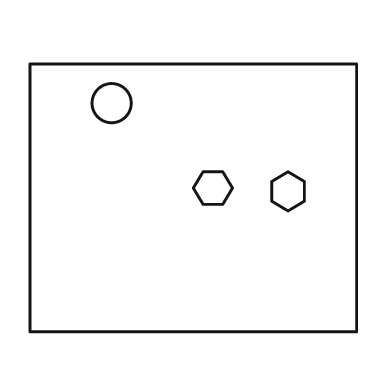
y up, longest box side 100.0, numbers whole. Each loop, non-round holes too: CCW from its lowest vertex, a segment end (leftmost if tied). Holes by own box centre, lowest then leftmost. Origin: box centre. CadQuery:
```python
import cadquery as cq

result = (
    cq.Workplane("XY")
    .moveTo(-50.0, -41.0)
    .lineTo(50.0, -41.0)
    .lineTo(50.0, 41.0)
    .lineTo(-50.0, 41.0)
    .close()
    .moveTo(29.0, -4.0)
    .lineTo(34.0, -1.0)
    .lineTo(34.0, 5.0)
    .lineTo(29.0, 8.0)
    .lineTo(24.0, 5.0)
    .lineTo(24.0, -1.0)
    .close()
    .moveTo(3.0, -2.0)
    .lineTo(9.0, -2.0)
    .lineTo(12.0, 3.0)
    .lineTo(9.0, 8.0)
    .lineTo(3.0, 8.0)
    .lineTo(0.0, 3.0)
    .close()
    .moveTo(-25.0, 29.0)
    .circle(6.0)
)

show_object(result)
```